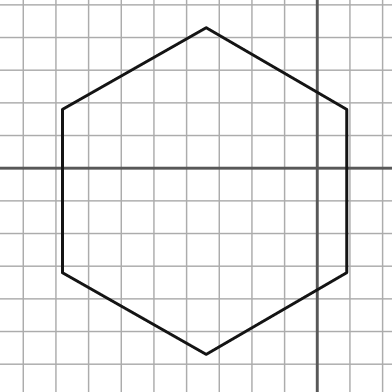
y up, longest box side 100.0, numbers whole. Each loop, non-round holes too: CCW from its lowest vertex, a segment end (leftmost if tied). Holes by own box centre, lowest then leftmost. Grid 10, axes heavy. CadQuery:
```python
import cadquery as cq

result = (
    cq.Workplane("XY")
    .moveTo(-34.0, -57.0)
    .lineTo(9.0, -32.0)
    .lineTo(9.0, 18.0)
    .lineTo(-34.0, 43.0)
    .lineTo(-78.0, 18.0)
    .lineTo(-78.0, -32.0)
    .close()
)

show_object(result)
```